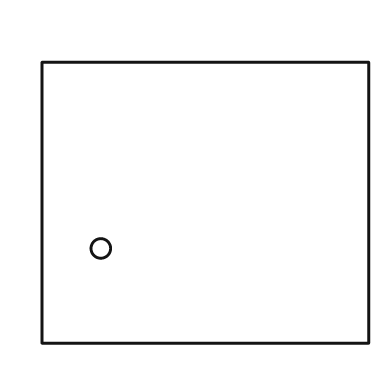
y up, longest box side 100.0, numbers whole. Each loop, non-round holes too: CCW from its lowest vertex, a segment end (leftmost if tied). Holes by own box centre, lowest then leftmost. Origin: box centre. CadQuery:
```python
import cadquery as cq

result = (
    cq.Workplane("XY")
    .moveTo(-50.0, -43.0)
    .lineTo(50.0, -43.0)
    .lineTo(50.0, 43.0)
    .lineTo(-50.0, 43.0)
    .close()
    .moveTo(-32.0, -14.0)
    .circle(3.0)
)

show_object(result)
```